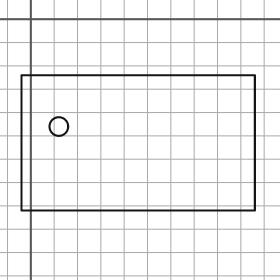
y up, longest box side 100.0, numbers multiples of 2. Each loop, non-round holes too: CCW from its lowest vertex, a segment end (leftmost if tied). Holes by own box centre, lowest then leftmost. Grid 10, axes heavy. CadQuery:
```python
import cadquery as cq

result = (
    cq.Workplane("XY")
    .moveTo(-4.0, -82.0)
    .lineTo(96.0, -82.0)
    .lineTo(96.0, -24.0)
    .lineTo(-4.0, -24.0)
    .close()
    .moveTo(12.0, -46.0)
    .circle(4.0)
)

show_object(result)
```